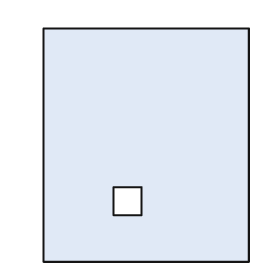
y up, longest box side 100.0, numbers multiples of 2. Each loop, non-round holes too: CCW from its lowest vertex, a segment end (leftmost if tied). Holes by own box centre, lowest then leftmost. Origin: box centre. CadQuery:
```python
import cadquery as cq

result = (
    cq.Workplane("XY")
    .moveTo(-44.0, -50.0)
    .lineTo(44.0, -50.0)
    .lineTo(44.0, 50.0)
    .lineTo(-44.0, 50.0)
    .close()
    .moveTo(-14.0, -30.0)
    .lineTo(-2.0, -30.0)
    .lineTo(-2.0, -18.0)
    .lineTo(-14.0, -18.0)
    .close()
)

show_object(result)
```